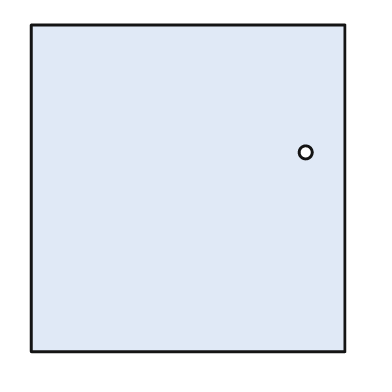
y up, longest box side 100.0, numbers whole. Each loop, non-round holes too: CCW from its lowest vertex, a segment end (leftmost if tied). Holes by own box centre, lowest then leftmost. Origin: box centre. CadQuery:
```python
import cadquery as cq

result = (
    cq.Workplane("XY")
    .moveTo(-48.0, -50.0)
    .lineTo(48.0, -50.0)
    .lineTo(48.0, 50.0)
    .lineTo(-48.0, 50.0)
    .close()
    .moveTo(36.0, 11.0)
    .circle(2.0)
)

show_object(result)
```